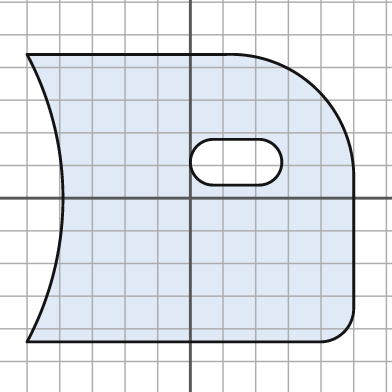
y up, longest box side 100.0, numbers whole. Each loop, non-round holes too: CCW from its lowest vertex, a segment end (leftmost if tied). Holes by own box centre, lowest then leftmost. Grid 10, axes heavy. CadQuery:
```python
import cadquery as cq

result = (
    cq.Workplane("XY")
    .moveTo(-50.0, -44.0)
    .lineTo(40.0, -44.0)
    .threePointArc((47.0, -41.0), (50.0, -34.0))
    .lineTo(50.0, 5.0)
    .threePointArc((39.0, 33.0), (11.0, 44.0))
    .lineTo(-50.0, 44.0)
    .threePointArc((-39.0, 0.0), (-50.0, -44.0))
    .close()
    .moveTo(7.0, 4.0)
    .lineTo(21.0, 4.0)
    .threePointArc((28.0, 11.0), (21.0, 18.0))
    .lineTo(7.0, 18.0)
    .threePointArc((0.0, 11.0), (7.0, 4.0))
    .close()
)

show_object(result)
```